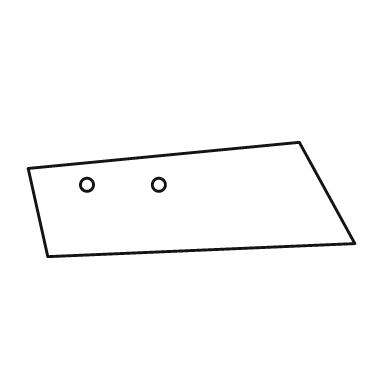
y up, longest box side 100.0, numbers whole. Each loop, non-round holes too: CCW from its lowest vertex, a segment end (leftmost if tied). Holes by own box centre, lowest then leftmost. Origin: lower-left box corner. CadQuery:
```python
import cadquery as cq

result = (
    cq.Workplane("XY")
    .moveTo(6.0, 0.0)
    .lineTo(100.0, 4.0)
    .lineTo(83.0, 35.0)
    .lineTo(0.0, 27.0)
    .close()
    .moveTo(18.0, 22.0)
    .circle(2.0)
    .moveTo(40.0, 22.0)
    .circle(2.0)
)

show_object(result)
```